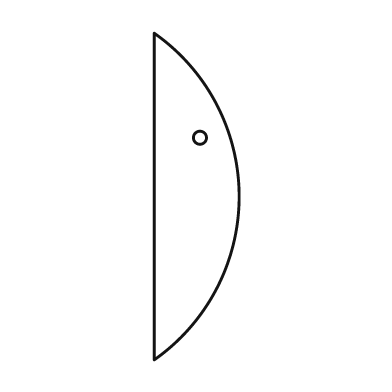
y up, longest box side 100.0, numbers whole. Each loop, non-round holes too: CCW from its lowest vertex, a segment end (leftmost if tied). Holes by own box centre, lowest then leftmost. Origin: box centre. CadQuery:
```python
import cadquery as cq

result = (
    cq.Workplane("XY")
    .moveTo(-13.0, -50.0)
    .threePointArc((13.0, 0.0), (-13.0, 50.0))
    .close()
    .moveTo(1.0, 18.0)
    .circle(2.0)
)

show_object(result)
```